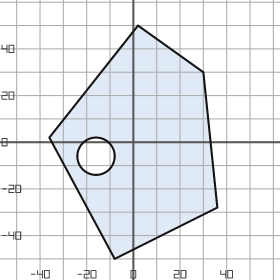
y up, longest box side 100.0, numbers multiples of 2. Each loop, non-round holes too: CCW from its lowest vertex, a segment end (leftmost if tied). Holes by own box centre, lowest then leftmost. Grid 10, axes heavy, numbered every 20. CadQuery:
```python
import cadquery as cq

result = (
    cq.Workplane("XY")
    .moveTo(-8.0, -50.0)
    .lineTo(36.0, -28.0)
    .lineTo(30.0, 30.0)
    .lineTo(2.0, 50.0)
    .lineTo(-36.0, 2.0)
    .close()
    .moveTo(-16.0, -6.0)
    .circle(8.0)
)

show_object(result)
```